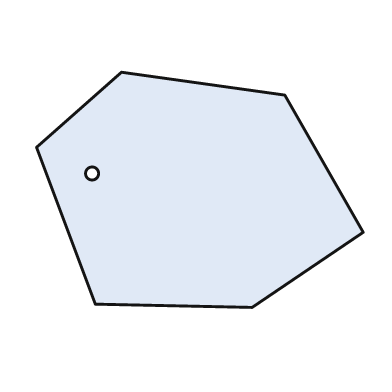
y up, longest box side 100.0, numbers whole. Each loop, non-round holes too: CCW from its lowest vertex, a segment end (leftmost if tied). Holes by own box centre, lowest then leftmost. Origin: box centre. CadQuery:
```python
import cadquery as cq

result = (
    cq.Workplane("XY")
    .moveTo(16.0, -36.0)
    .lineTo(50.0, -13.0)
    .lineTo(26.0, 29.0)
    .lineTo(-24.0, 36.0)
    .lineTo(-50.0, 13.0)
    .lineTo(-32.0, -35.0)
    .close()
    .moveTo(-33.0, 5.0)
    .circle(2.0)
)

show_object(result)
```